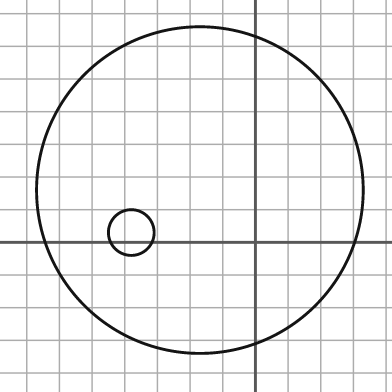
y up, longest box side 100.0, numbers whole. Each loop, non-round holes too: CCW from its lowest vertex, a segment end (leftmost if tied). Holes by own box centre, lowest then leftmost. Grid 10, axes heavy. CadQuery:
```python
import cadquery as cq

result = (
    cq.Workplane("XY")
    .moveTo(-17.0, 16.0)
    .circle(50.0)
    .moveTo(-38.0, 3.0)
    .circle(7.0)
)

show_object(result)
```